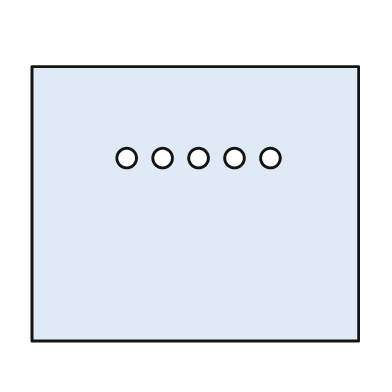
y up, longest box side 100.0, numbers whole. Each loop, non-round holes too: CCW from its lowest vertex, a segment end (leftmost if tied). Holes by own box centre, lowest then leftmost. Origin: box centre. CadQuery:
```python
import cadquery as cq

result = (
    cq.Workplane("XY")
    .moveTo(-50.0, -42.0)
    .lineTo(50.0, -42.0)
    .lineTo(50.0, 42.0)
    .lineTo(-50.0, 42.0)
    .close()
    .moveTo(-21.0, 14.0)
    .circle(3.0)
    .moveTo(-10.0, 14.0)
    .circle(3.0)
    .moveTo(1.0, 14.0)
    .circle(3.0)
    .moveTo(12.0, 14.0)
    .circle(3.0)
    .moveTo(23.0, 14.0)
    .circle(3.0)
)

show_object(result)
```